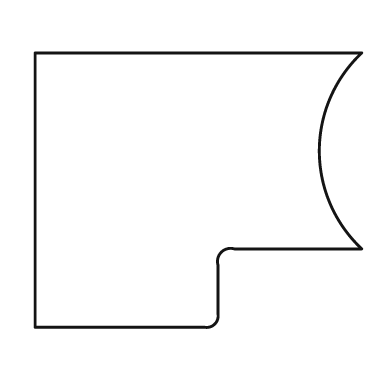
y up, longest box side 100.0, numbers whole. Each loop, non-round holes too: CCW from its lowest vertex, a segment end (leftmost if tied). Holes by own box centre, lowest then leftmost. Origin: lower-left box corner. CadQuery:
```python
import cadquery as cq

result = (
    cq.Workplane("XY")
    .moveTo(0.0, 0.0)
    .lineTo(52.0, 0.0)
    .threePointArc((55.0, 1.0), (56.0, 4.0))
    .lineTo(56.0, 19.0)
    .threePointArc((57.0, 23.0), (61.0, 24.0))
    .lineTo(100.0, 24.0)
    .threePointArc((87.0, 54.0), (100.0, 84.0))
    .lineTo(0.0, 84.0)
    .close()
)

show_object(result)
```